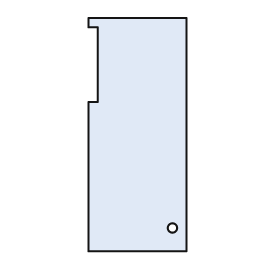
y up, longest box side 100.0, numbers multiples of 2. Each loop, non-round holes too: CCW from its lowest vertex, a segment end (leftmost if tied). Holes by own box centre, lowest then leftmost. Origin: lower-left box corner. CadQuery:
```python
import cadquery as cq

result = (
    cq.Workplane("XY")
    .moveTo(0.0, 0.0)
    .lineTo(42.0, 0.0)
    .lineTo(42.0, 100.0)
    .lineTo(0.0, 100.0)
    .lineTo(0.0, 96.0)
    .lineTo(4.0, 96.0)
    .lineTo(4.0, 64.0)
    .lineTo(0.0, 64.0)
    .close()
    .moveTo(36.0, 10.0)
    .circle(2.0)
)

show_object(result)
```